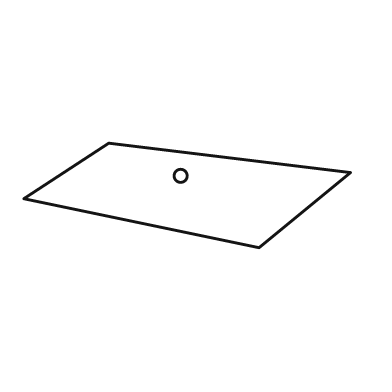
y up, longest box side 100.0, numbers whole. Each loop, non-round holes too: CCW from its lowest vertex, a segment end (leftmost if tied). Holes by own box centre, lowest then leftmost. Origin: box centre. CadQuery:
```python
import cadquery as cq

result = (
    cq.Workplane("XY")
    .moveTo(22.0, -16.0)
    .lineTo(50.0, 7.0)
    .lineTo(-24.0, 16.0)
    .lineTo(-50.0, -1.0)
    .close()
    .moveTo(-2.0, 6.0)
    .circle(2.0)
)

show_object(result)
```